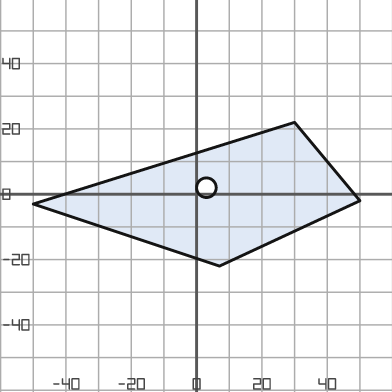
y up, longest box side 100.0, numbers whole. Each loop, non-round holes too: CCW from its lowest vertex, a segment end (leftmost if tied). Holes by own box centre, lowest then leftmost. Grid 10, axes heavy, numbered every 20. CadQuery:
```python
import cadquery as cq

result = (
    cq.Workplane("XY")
    .moveTo(7.0, -22.0)
    .lineTo(50.0, -2.0)
    .lineTo(30.0, 22.0)
    .lineTo(-50.0, -3.0)
    .close()
    .moveTo(3.0, 2.0)
    .circle(3.0)
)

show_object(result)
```